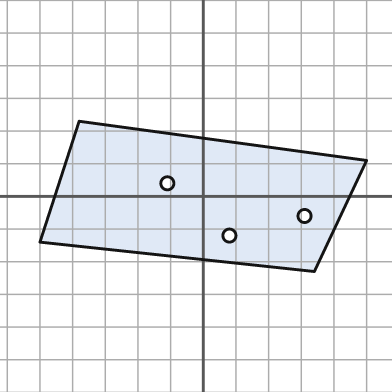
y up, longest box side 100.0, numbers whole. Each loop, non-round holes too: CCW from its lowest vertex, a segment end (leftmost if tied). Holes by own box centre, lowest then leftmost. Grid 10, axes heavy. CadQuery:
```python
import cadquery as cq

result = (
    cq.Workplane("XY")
    .moveTo(34.0, -23.0)
    .lineTo(50.0, 11.0)
    .lineTo(-38.0, 23.0)
    .lineTo(-50.0, -14.0)
    .close()
    .moveTo(8.0, -12.0)
    .circle(2.0)
    .moveTo(31.0, -6.0)
    .circle(2.0)
    .moveTo(-11.0, 4.0)
    .circle(2.0)
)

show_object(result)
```